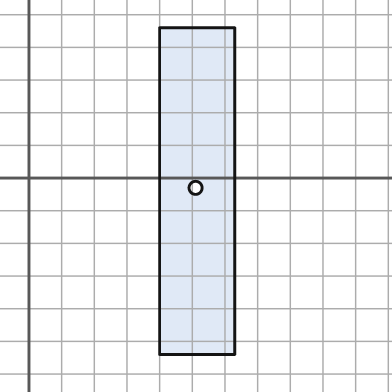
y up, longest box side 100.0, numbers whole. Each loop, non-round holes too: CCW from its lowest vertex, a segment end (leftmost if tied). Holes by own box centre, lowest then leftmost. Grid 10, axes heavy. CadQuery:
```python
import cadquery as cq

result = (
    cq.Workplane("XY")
    .moveTo(40.0, -54.0)
    .lineTo(63.0, -54.0)
    .lineTo(63.0, 46.0)
    .lineTo(40.0, 46.0)
    .close()
    .moveTo(51.0, -3.0)
    .circle(2.0)
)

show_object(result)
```